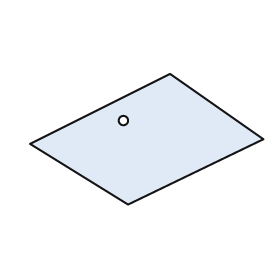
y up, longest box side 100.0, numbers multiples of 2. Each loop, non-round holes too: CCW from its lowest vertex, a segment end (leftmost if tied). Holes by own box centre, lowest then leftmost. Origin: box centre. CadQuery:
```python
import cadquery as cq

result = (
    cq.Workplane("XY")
    .moveTo(-8.0, -28.0)
    .lineTo(50.0, 0.0)
    .lineTo(10.0, 28.0)
    .lineTo(-50.0, -2.0)
    .close()
    .moveTo(-10.0, 8.0)
    .circle(2.0)
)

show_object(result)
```